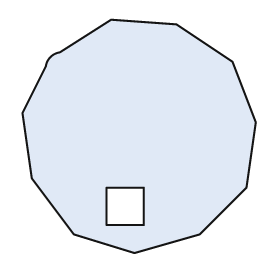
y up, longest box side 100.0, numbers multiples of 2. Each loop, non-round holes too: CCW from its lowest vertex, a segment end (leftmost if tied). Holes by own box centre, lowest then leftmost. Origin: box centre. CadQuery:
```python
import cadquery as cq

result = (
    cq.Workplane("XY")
    .moveTo(-2.0, -50.0)
    .lineTo(26.0, -42.0)
    .lineTo(46.0, -22.0)
    .lineTo(50.0, 6.0)
    .lineTo(40.0, 32.0)
    .lineTo(16.0, 48.0)
    .lineTo(-12.0, 50.0)
    .lineTo(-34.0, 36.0)
    .threePointArc((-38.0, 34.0), (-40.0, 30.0))
    .lineTo(-50.0, 10.0)
    .lineTo(-46.0, -18.0)
    .lineTo(-28.0, -42.0)
    .close()
    .moveTo(-14.0, -38.0)
    .lineTo(2.0, -38.0)
    .lineTo(2.0, -22.0)
    .lineTo(-14.0, -22.0)
    .close()
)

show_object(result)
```